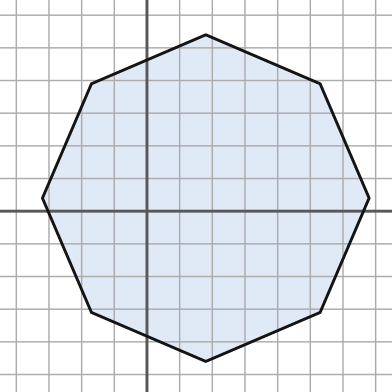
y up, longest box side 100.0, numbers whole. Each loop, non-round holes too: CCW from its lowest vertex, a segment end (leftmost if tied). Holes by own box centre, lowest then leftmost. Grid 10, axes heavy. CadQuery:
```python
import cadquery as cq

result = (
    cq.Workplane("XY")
    .moveTo(18.0, -46.0)
    .lineTo(53.0, -31.0)
    .lineTo(68.0, 4.0)
    .lineTo(53.0, 39.0)
    .lineTo(18.0, 54.0)
    .lineTo(-17.0, 39.0)
    .lineTo(-32.0, 4.0)
    .lineTo(-17.0, -31.0)
    .close()
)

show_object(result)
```